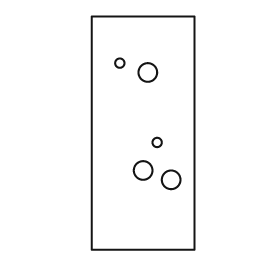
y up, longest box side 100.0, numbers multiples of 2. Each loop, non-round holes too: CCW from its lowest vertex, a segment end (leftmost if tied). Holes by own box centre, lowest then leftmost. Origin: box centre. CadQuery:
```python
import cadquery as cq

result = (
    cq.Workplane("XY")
    .moveTo(-22.0, -50.0)
    .lineTo(22.0, -50.0)
    .lineTo(22.0, 50.0)
    .lineTo(-22.0, 50.0)
    .close()
    .moveTo(12.0, -20.0)
    .circle(4.0)
    .moveTo(0.0, -16.0)
    .circle(4.0)
    .moveTo(6.0, -4.0)
    .circle(2.0)
    .moveTo(2.0, 26.0)
    .circle(4.0)
    .moveTo(-10.0, 30.0)
    .circle(2.0)
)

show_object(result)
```